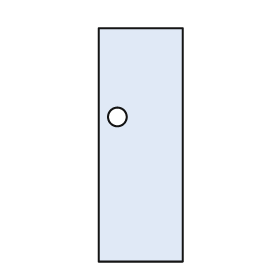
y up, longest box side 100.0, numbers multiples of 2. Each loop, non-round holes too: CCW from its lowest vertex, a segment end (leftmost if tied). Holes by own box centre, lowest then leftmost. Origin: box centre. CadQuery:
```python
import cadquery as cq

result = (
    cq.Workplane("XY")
    .moveTo(-18.0, -50.0)
    .lineTo(18.0, -50.0)
    .lineTo(18.0, 50.0)
    .lineTo(-18.0, 50.0)
    .close()
    .moveTo(-10.0, 12.0)
    .circle(4.0)
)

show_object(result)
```